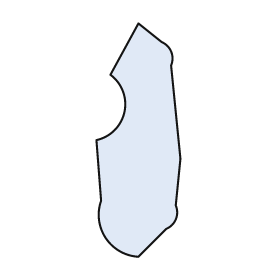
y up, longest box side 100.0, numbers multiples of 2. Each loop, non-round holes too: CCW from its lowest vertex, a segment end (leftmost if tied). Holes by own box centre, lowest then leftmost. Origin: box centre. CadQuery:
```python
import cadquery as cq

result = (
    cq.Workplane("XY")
    .moveTo(0.0, -50.0)
    .lineTo(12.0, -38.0)
    .threePointArc((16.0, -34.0), (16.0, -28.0))
    .lineTo(18.0, -8.0)
    .lineTo(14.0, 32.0)
    .threePointArc((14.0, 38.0), (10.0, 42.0))
    .lineTo(0.0, 50.0)
    .lineTo(-12.0, 28.0)
    .threePointArc((-6.0, 12.0), (-18.0, 0.0))
    .lineTo(-16.0, -26.0)
    .threePointArc((-14.0, -42.0), (0.0, -50.0))
    .close()
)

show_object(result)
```